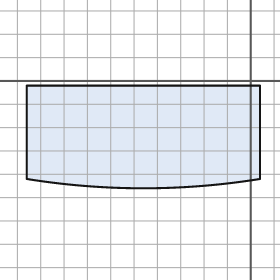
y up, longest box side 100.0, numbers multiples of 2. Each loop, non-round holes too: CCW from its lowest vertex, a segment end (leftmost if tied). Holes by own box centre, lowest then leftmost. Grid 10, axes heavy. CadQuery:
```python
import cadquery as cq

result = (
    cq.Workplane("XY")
    .moveTo(-96.0, -42.0)
    .threePointArc((-46.0, -46.0), (4.0, -42.0))
    .lineTo(4.0, -2.0)
    .lineTo(-96.0, -2.0)
    .close()
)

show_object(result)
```